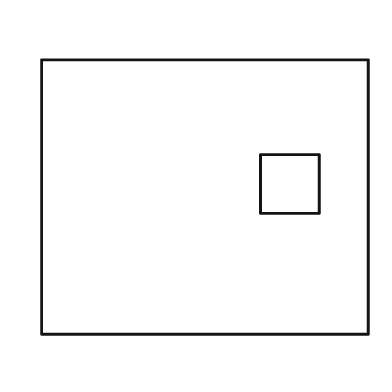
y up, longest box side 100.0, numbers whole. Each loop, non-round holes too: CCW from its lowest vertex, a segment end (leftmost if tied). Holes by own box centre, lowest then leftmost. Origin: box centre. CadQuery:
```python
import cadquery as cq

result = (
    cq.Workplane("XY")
    .moveTo(-50.0, -42.0)
    .lineTo(50.0, -42.0)
    .lineTo(50.0, 42.0)
    .lineTo(-50.0, 42.0)
    .close()
    .moveTo(17.0, -5.0)
    .lineTo(35.0, -5.0)
    .lineTo(35.0, 13.0)
    .lineTo(17.0, 13.0)
    .close()
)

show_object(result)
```